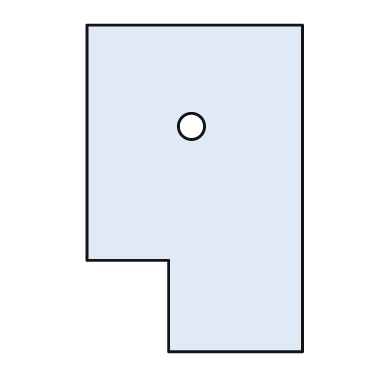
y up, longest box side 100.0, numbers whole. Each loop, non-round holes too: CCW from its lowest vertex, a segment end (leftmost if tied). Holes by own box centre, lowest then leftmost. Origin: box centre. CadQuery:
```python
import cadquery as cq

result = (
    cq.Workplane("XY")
    .moveTo(-8.0, -50.0)
    .lineTo(33.0, -50.0)
    .lineTo(33.0, 50.0)
    .lineTo(-33.0, 50.0)
    .lineTo(-33.0, -22.0)
    .lineTo(-8.0, -22.0)
    .close()
    .moveTo(-1.0, 19.0)
    .circle(4.0)
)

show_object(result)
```